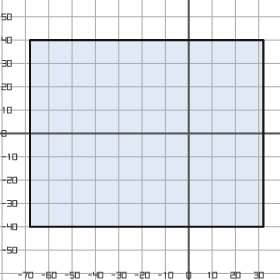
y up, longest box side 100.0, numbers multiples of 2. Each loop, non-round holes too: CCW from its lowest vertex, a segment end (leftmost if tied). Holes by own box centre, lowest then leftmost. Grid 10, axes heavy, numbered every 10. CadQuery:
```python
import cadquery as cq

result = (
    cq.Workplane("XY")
    .moveTo(-68.0, -40.0)
    .lineTo(32.0, -40.0)
    .lineTo(32.0, 40.0)
    .lineTo(-68.0, 40.0)
    .close()
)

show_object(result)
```